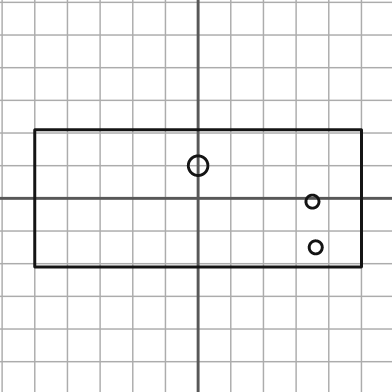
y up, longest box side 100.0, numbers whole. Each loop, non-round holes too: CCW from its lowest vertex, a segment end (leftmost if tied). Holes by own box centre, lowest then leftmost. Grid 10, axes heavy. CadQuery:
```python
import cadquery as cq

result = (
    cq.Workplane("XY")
    .moveTo(-50.0, -21.0)
    .lineTo(50.0, -21.0)
    .lineTo(50.0, 21.0)
    .lineTo(-50.0, 21.0)
    .close()
    .moveTo(36.0, -15.0)
    .circle(2.0)
    .moveTo(35.0, -1.0)
    .circle(2.0)
    .moveTo(0.0, 10.0)
    .circle(3.0)
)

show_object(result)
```